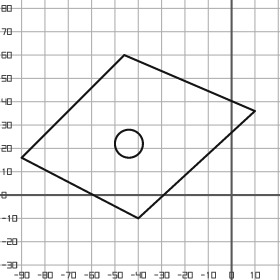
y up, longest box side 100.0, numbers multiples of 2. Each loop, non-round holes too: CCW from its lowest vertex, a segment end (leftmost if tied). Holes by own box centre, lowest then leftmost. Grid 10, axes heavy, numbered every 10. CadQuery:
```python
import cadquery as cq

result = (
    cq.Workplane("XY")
    .moveTo(-40.0, -10.0)
    .lineTo(10.0, 36.0)
    .lineTo(-46.0, 60.0)
    .lineTo(-90.0, 16.0)
    .close()
    .moveTo(-44.0, 22.0)
    .circle(6.0)
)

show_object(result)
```